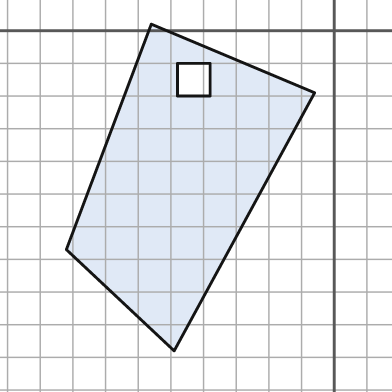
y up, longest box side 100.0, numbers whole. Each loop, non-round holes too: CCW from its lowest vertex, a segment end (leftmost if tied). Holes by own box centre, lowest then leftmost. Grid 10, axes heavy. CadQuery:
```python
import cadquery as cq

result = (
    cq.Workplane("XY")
    .moveTo(-49.0, -98.0)
    .lineTo(-6.0, -19.0)
    .lineTo(-56.0, 2.0)
    .lineTo(-82.0, -67.0)
    .close()
    .moveTo(-48.0, -20.0)
    .lineTo(-38.0, -20.0)
    .lineTo(-38.0, -10.0)
    .lineTo(-48.0, -10.0)
    .close()
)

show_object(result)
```